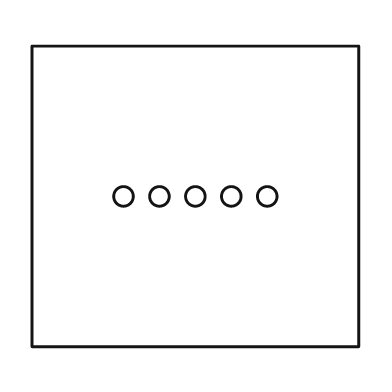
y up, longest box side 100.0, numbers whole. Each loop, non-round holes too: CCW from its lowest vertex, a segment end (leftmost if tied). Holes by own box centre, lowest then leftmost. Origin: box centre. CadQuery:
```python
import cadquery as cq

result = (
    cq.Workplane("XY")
    .moveTo(-50.0, -46.0)
    .lineTo(50.0, -46.0)
    .lineTo(50.0, 46.0)
    .lineTo(-50.0, 46.0)
    .close()
    .moveTo(-22.0, 0.0)
    .circle(3.0)
    .moveTo(-11.0, 0.0)
    .circle(3.0)
    .moveTo(0.0, 0.0)
    .circle(3.0)
    .moveTo(11.0, 0.0)
    .circle(3.0)
    .moveTo(22.0, 0.0)
    .circle(3.0)
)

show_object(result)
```